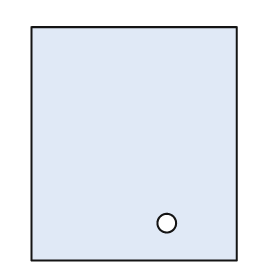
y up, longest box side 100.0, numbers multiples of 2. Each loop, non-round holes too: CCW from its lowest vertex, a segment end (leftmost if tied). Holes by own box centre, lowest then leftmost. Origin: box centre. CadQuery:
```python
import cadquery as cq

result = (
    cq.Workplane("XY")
    .moveTo(-44.0, -50.0)
    .lineTo(44.0, -50.0)
    .lineTo(44.0, 50.0)
    .lineTo(-44.0, 50.0)
    .close()
    .moveTo(14.0, -34.0)
    .circle(4.0)
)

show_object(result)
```